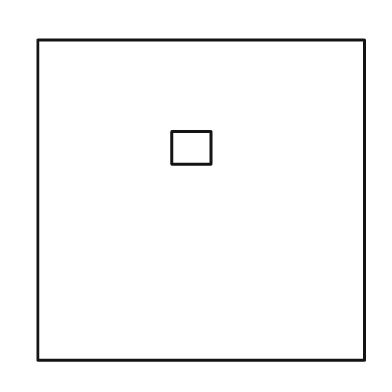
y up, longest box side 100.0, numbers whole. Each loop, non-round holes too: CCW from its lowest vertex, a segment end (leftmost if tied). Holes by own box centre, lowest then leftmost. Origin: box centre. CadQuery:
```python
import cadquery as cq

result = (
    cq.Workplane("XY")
    .moveTo(-50.0, -49.0)
    .lineTo(50.0, -49.0)
    .lineTo(50.0, 49.0)
    .lineTo(-50.0, 49.0)
    .close()
    .moveTo(-9.0, 11.0)
    .lineTo(3.0, 11.0)
    .lineTo(3.0, 21.0)
    .lineTo(-9.0, 21.0)
    .close()
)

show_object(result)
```